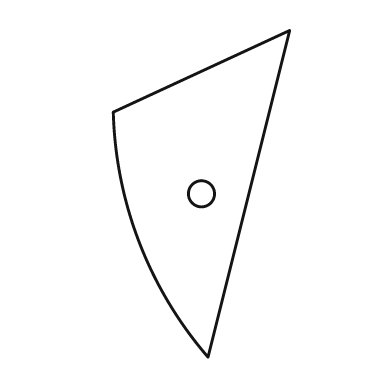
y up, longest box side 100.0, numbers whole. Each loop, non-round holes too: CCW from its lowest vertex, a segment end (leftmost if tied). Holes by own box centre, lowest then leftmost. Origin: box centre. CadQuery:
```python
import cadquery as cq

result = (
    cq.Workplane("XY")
    .moveTo(2.0, -50.0)
    .lineTo(27.0, 50.0)
    .lineTo(-27.0, 25.0)
    .threePointArc((-19.0, -15.0), (2.0, -50.0))
    .close()
    .moveTo(0.0, 0.0)
    .circle(4.0)
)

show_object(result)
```